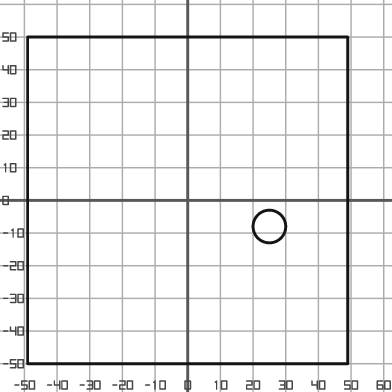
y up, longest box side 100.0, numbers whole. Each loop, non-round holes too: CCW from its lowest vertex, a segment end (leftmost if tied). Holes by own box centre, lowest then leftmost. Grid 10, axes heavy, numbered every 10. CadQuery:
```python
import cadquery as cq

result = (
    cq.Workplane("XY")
    .moveTo(-49.0, -50.0)
    .lineTo(49.0, -50.0)
    .lineTo(49.0, 50.0)
    .lineTo(-49.0, 50.0)
    .close()
    .moveTo(25.0, -8.0)
    .circle(5.0)
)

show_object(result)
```